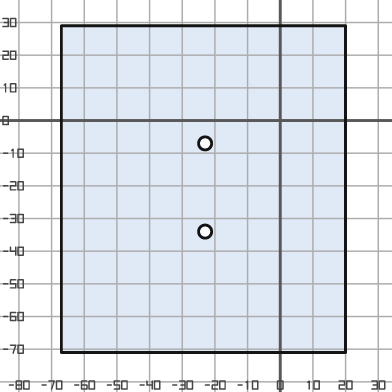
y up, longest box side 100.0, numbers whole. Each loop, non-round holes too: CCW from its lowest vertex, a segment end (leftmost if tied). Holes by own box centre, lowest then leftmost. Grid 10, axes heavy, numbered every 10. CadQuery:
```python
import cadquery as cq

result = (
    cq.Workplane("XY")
    .moveTo(-67.0, -71.0)
    .lineTo(20.0, -71.0)
    .lineTo(20.0, 29.0)
    .lineTo(-67.0, 29.0)
    .close()
    .moveTo(-23.0, -34.0)
    .circle(2.0)
    .moveTo(-23.0, -7.0)
    .circle(2.0)
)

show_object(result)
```